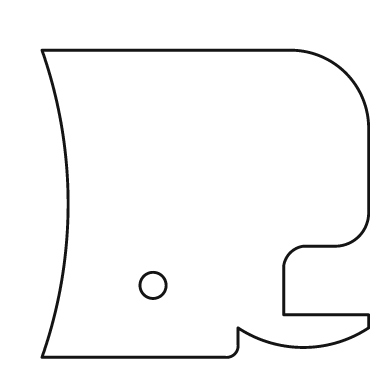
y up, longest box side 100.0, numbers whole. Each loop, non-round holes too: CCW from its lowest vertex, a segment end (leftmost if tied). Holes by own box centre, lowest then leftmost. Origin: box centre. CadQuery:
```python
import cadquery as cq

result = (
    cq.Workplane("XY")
    .moveTo(-50.0, -47.0)
    .lineTo(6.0, -47.0)
    .threePointArc((9.0, -46.0), (10.0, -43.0))
    .lineTo(10.0, -38.0)
    .threePointArc((30.0, -44.0), (50.0, -38.0))
    .lineTo(50.0, -34.0)
    .lineTo(24.0, -34.0)
    .lineTo(24.0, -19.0)
    .threePointArc((26.0, -15.0), (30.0, -13.0))
    .lineTo(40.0, -13.0)
    .threePointArc((47.0, -10.0), (50.0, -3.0))
    .lineTo(50.0, 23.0)
    .threePointArc((43.0, 40.0), (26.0, 47.0))
    .lineTo(-50.0, 47.0)
    .threePointArc((-42.0, 0.0), (-50.0, -47.0))
    .close()
    .moveTo(-16.0, -25.0)
    .circle(4.0)
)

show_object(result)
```